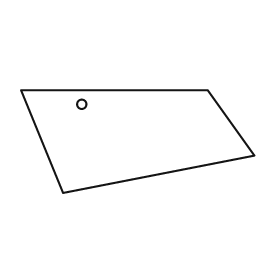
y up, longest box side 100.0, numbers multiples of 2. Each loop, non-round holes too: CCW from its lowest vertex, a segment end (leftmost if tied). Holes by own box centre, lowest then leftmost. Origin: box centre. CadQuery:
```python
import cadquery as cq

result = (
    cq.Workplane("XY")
    .moveTo(-32.0, -22.0)
    .lineTo(50.0, -6.0)
    .lineTo(30.0, 22.0)
    .lineTo(-50.0, 22.0)
    .close()
    .moveTo(-24.0, 16.0)
    .circle(2.0)
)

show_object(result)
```